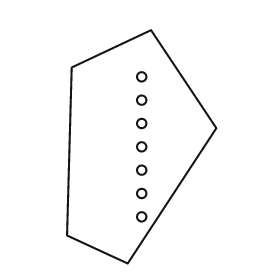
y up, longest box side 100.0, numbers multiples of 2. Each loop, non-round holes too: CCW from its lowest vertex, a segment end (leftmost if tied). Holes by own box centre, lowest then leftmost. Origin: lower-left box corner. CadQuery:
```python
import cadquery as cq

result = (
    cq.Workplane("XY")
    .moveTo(26.0, 0.0)
    .lineTo(64.0, 58.0)
    .lineTo(36.0, 100.0)
    .lineTo(2.0, 84.0)
    .lineTo(0.0, 12.0)
    .close()
    .moveTo(32.0, 20.0)
    .circle(2.0)
    .moveTo(32.0, 30.0)
    .circle(2.0)
    .moveTo(32.0, 40.0)
    .circle(2.0)
    .moveTo(32.0, 50.0)
    .circle(2.0)
    .moveTo(32.0, 60.0)
    .circle(2.0)
    .moveTo(32.0, 70.0)
    .circle(2.0)
    .moveTo(32.0, 80.0)
    .circle(2.0)
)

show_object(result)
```